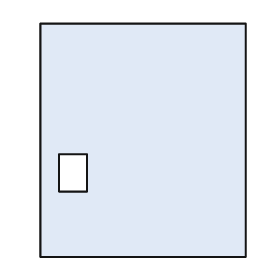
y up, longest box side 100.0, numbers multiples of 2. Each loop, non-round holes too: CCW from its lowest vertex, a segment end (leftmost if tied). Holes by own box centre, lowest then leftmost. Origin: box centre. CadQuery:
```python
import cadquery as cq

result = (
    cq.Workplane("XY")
    .moveTo(-44.0, -50.0)
    .lineTo(44.0, -50.0)
    .lineTo(44.0, 50.0)
    .lineTo(-44.0, 50.0)
    .close()
    .moveTo(-36.0, -22.0)
    .lineTo(-24.0, -22.0)
    .lineTo(-24.0, -6.0)
    .lineTo(-36.0, -6.0)
    .close()
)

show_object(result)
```